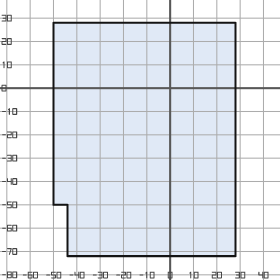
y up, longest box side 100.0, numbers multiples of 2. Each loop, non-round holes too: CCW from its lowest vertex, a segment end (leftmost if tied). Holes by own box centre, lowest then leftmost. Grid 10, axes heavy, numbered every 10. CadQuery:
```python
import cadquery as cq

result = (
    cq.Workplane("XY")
    .moveTo(-44.0, -72.0)
    .lineTo(28.0, -72.0)
    .lineTo(28.0, 28.0)
    .lineTo(-50.0, 28.0)
    .lineTo(-50.0, -50.0)
    .lineTo(-44.0, -50.0)
    .close()
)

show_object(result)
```